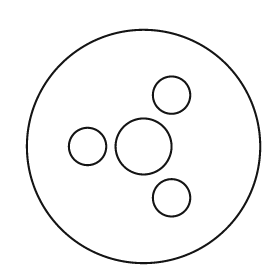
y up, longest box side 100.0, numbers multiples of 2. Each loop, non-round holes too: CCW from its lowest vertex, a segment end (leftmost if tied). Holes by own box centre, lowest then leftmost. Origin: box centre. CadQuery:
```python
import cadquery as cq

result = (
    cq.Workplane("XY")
    .moveTo(0.0, 0.0)
    .circle(50.0)
    .moveTo(12.0, -22.0)
    .circle(8.0)
    .moveTo(-24.0, 0.0)
    .circle(8.0)
    .moveTo(0.0, 0.0)
    .circle(12.0)
    .moveTo(12.0, 22.0)
    .circle(8.0)
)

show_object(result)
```